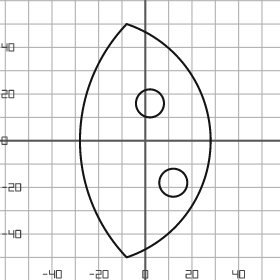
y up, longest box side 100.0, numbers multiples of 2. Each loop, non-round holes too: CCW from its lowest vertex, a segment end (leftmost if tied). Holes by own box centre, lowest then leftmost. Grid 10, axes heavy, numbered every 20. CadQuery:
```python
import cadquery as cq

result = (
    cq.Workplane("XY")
    .moveTo(-8.0, -50.0)
    .threePointArc((28.0, 0.0), (-8.0, 50.0))
    .threePointArc((-28.0, 0.0), (-8.0, -50.0))
    .close()
    .moveTo(12.0, -18.0)
    .circle(6.0)
    .moveTo(2.0, 16.0)
    .circle(6.0)
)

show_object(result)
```